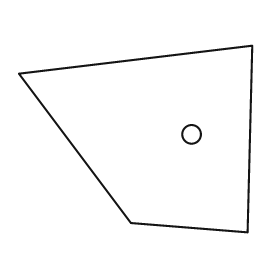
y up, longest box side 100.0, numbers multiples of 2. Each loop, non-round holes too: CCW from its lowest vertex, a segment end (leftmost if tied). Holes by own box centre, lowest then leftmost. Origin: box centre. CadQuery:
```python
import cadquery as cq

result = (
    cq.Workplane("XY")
    .moveTo(48.0, -40.0)
    .lineTo(50.0, 40.0)
    .lineTo(-50.0, 28.0)
    .lineTo(-2.0, -36.0)
    .close()
    .moveTo(24.0, 2.0)
    .circle(4.0)
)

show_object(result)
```